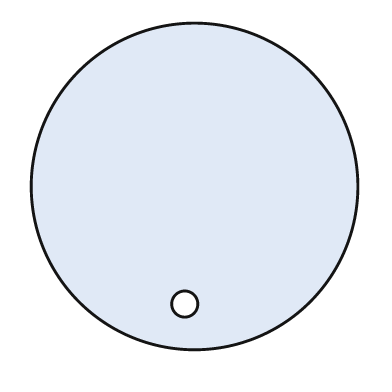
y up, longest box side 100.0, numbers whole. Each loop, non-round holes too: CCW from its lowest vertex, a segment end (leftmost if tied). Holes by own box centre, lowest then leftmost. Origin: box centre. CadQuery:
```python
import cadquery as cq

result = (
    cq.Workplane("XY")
    .moveTo(0.0, 0.0)
    .circle(50.0)
    .moveTo(-3.0, -36.0)
    .circle(4.0)
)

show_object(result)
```